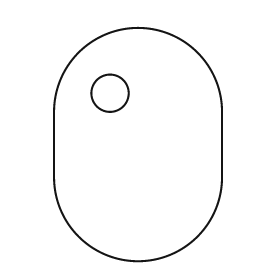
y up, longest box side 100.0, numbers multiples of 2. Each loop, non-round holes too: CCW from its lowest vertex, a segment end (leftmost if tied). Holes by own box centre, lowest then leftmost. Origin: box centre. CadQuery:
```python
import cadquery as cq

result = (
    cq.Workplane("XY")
    .moveTo(-36.0, -14.0)
    .threePointArc((0.0, -50.0), (36.0, -14.0))
    .lineTo(36.0, 14.0)
    .threePointArc((0.0, 50.0), (-36.0, 14.0))
    .close()
    .moveTo(-12.0, 22.0)
    .circle(8.0)
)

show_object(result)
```